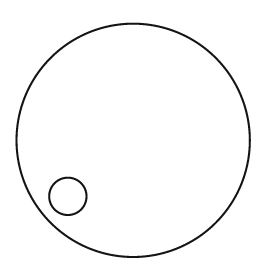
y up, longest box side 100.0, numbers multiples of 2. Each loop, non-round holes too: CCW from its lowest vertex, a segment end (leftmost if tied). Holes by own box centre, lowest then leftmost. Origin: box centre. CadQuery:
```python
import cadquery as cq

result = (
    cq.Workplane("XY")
    .moveTo(0.0, 0.0)
    .circle(50.0)
    .moveTo(-28.0, -24.0)
    .circle(8.0)
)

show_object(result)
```